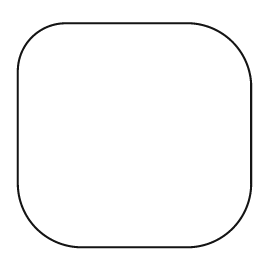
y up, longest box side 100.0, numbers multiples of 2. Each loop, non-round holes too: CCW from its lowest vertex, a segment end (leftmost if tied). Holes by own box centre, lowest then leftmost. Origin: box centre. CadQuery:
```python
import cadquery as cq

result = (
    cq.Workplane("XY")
    .moveTo(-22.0, -48.0)
    .lineTo(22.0, -48.0)
    .threePointArc((42.0, -40.0), (50.0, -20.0))
    .lineTo(50.0, 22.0)
    .threePointArc((42.0, 40.0), (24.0, 48.0))
    .lineTo(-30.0, 48.0)
    .threePointArc((-44.0, 42.0), (-50.0, 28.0))
    .lineTo(-50.0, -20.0)
    .threePointArc((-42.0, -40.0), (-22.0, -48.0))
    .close()
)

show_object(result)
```